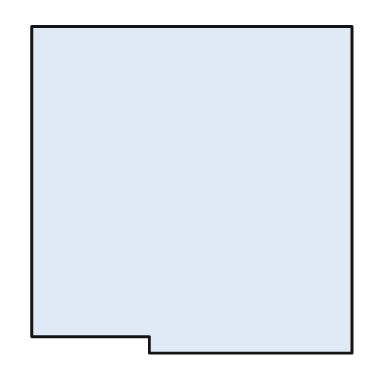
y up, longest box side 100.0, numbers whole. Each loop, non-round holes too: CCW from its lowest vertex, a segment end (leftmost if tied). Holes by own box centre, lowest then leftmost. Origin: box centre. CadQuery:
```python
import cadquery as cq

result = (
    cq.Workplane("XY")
    .moveTo(-13.0, -50.0)
    .lineTo(49.0, -50.0)
    .lineTo(49.0, 50.0)
    .lineTo(-49.0, 50.0)
    .lineTo(-49.0, -45.0)
    .lineTo(-13.0, -45.0)
    .close()
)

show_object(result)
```